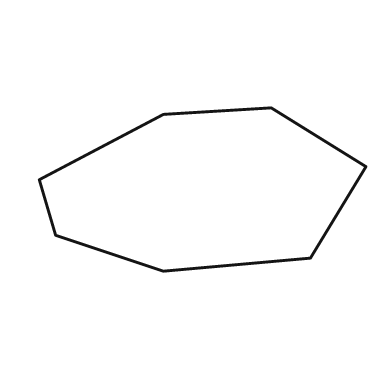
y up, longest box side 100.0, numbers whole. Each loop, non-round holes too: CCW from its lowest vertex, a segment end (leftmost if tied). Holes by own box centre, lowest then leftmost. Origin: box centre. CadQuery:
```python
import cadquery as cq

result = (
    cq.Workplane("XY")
    .moveTo(-12.0, -25.0)
    .lineTo(33.0, -21.0)
    .lineTo(50.0, 7.0)
    .lineTo(21.0, 25.0)
    .lineTo(-12.0, 23.0)
    .lineTo(-50.0, 3.0)
    .lineTo(-45.0, -14.0)
    .close()
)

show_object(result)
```